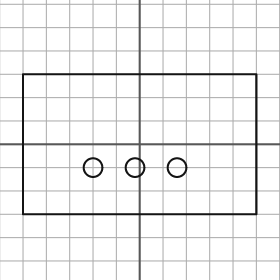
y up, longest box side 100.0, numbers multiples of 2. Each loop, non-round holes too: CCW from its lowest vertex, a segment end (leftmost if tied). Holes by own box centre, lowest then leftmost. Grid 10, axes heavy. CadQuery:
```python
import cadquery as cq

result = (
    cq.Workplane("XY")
    .moveTo(-50.0, -30.0)
    .lineTo(50.0, -30.0)
    .lineTo(50.0, 30.0)
    .lineTo(-50.0, 30.0)
    .close()
    .moveTo(-20.0, -10.0)
    .circle(4.0)
    .moveTo(-2.0, -10.0)
    .circle(4.0)
    .moveTo(16.0, -10.0)
    .circle(4.0)
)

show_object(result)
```